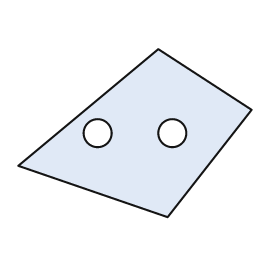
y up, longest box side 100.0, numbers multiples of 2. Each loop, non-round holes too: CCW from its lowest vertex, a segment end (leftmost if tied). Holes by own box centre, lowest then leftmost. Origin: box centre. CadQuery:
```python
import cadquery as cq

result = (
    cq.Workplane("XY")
    .moveTo(14.0, -36.0)
    .lineTo(50.0, 10.0)
    .lineTo(10.0, 36.0)
    .lineTo(-50.0, -14.0)
    .close()
    .moveTo(-16.0, 0.0)
    .circle(6.0)
    .moveTo(16.0, 0.0)
    .circle(6.0)
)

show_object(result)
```